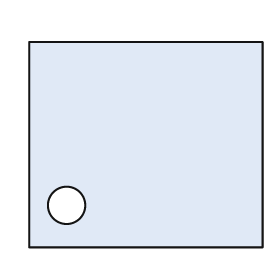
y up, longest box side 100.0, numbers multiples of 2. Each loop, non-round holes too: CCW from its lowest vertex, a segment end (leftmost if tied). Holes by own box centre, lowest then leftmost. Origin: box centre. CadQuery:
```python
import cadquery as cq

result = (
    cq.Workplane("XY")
    .moveTo(-50.0, -44.0)
    .lineTo(50.0, -44.0)
    .lineTo(50.0, 44.0)
    .lineTo(-50.0, 44.0)
    .close()
    .moveTo(-34.0, -26.0)
    .circle(8.0)
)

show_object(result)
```